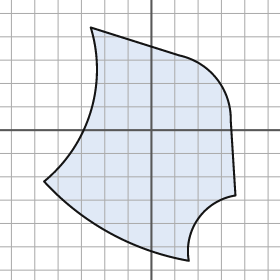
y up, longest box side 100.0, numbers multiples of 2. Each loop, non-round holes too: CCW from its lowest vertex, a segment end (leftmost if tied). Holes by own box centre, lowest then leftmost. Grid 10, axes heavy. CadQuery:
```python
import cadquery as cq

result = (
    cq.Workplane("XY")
    .moveTo(16.0, -56.0)
    .threePointArc((20.0, -38.0), (36.0, -28.0))
    .lineTo(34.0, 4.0)
    .threePointArc((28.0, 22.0), (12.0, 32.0))
    .lineTo(-26.0, 44.0)
    .threePointArc((-26.0, 8.0), (-46.0, -22.0))
    .threePointArc((-18.0, -44.0), (16.0, -56.0))
    .close()
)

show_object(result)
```